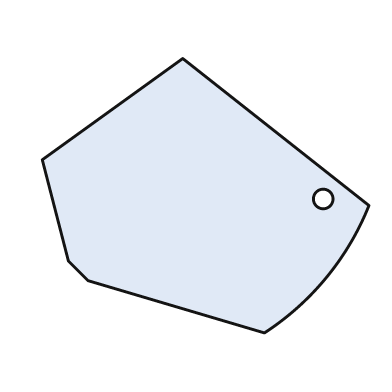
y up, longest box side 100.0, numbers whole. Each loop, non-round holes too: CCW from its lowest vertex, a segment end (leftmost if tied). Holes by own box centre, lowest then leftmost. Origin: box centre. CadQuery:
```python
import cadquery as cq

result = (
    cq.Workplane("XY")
    .moveTo(18.0, -42.0)
    .threePointArc((37.0, -25.0), (50.0, -3.0))
    .lineTo(-7.0, 42.0)
    .lineTo(-50.0, 11.0)
    .lineTo(-42.0, -20.0)
    .lineTo(-36.0, -26.0)
    .close()
    .moveTo(36.0, -1.0)
    .circle(3.0)
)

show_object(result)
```